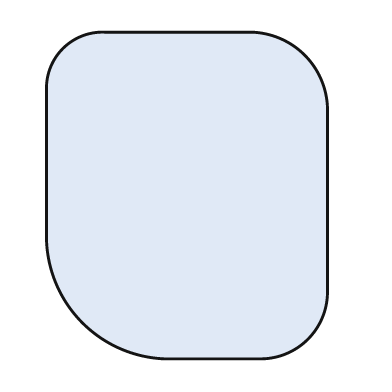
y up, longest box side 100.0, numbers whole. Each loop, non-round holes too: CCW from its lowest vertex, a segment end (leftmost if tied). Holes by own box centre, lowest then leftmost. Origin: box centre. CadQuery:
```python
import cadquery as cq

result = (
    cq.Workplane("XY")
    .moveTo(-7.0, -50.0)
    .lineTo(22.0, -50.0)
    .threePointArc((37.0, -44.0), (43.0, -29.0))
    .lineTo(43.0, 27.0)
    .threePointArc((36.0, 43.0), (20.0, 50.0))
    .lineTo(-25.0, 50.0)
    .threePointArc((-38.0, 45.0), (-43.0, 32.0))
    .lineTo(-43.0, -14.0)
    .threePointArc((-32.0, -39.0), (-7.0, -50.0))
    .close()
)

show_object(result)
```